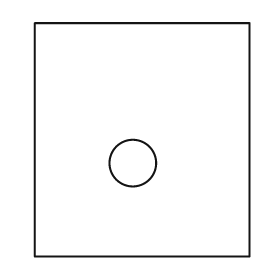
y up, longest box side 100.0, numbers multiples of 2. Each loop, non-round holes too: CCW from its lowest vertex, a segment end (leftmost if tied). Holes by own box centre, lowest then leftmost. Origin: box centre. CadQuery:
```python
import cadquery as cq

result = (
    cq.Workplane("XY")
    .moveTo(-46.0, -50.0)
    .lineTo(46.0, -50.0)
    .lineTo(46.0, 50.0)
    .lineTo(-46.0, 50.0)
    .close()
    .moveTo(-4.0, -10.0)
    .circle(10.0)
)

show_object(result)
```